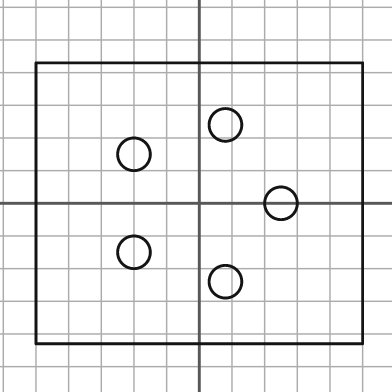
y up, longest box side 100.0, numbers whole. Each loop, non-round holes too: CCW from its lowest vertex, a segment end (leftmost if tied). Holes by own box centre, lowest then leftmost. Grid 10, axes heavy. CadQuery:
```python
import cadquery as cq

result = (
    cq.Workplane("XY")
    .moveTo(-50.0, -43.0)
    .lineTo(50.0, -43.0)
    .lineTo(50.0, 43.0)
    .lineTo(-50.0, 43.0)
    .close()
    .moveTo(8.0, -24.0)
    .circle(5.0)
    .moveTo(-20.0, -15.0)
    .circle(5.0)
    .moveTo(25.0, 0.0)
    .circle(5.0)
    .moveTo(-20.0, 15.0)
    .circle(5.0)
    .moveTo(8.0, 24.0)
    .circle(5.0)
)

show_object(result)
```